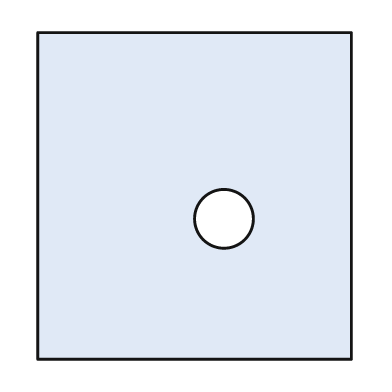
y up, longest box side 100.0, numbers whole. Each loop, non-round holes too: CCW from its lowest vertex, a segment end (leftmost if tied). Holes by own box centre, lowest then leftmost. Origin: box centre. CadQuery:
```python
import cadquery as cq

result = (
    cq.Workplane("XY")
    .moveTo(-48.0, -50.0)
    .lineTo(48.0, -50.0)
    .lineTo(48.0, 50.0)
    .lineTo(-48.0, 50.0)
    .close()
    .moveTo(9.0, -7.0)
    .circle(9.0)
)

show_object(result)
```